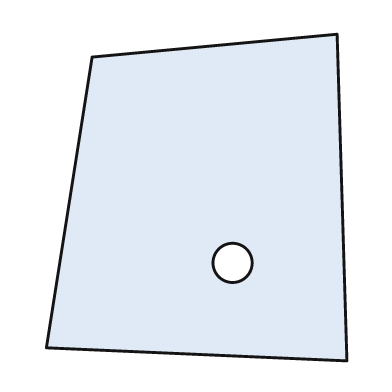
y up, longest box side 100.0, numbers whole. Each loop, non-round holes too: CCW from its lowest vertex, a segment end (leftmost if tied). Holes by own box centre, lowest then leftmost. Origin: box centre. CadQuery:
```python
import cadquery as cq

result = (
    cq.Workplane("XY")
    .moveTo(46.0, -50.0)
    .lineTo(43.0, 50.0)
    .lineTo(-32.0, 43.0)
    .lineTo(-46.0, -46.0)
    .close()
    .moveTo(11.0, -20.0)
    .circle(6.0)
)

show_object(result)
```